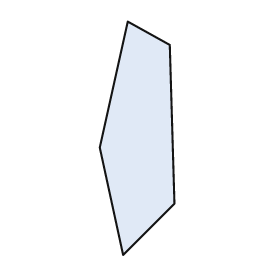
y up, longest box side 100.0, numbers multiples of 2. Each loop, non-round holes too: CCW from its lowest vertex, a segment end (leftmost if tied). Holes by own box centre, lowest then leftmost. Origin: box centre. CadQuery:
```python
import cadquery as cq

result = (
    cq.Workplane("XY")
    .moveTo(-6.0, -50.0)
    .lineTo(16.0, -28.0)
    .lineTo(14.0, 40.0)
    .lineTo(-4.0, 50.0)
    .lineTo(-16.0, -4.0)
    .close()
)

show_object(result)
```